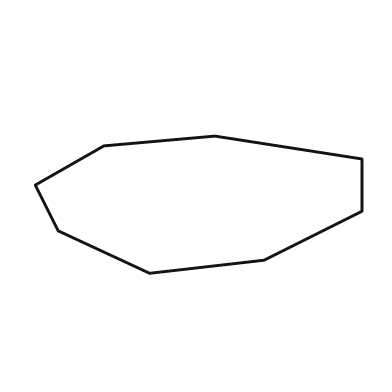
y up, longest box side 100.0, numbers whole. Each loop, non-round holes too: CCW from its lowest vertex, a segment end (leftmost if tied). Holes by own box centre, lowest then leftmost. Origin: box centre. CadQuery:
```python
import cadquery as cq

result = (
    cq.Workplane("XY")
    .moveTo(-15.0, -21.0)
    .lineTo(20.0, -17.0)
    .lineTo(50.0, -2.0)
    .lineTo(50.0, 14.0)
    .lineTo(5.0, 21.0)
    .lineTo(-29.0, 18.0)
    .lineTo(-50.0, 6.0)
    .lineTo(-43.0, -8.0)
    .close()
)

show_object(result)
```